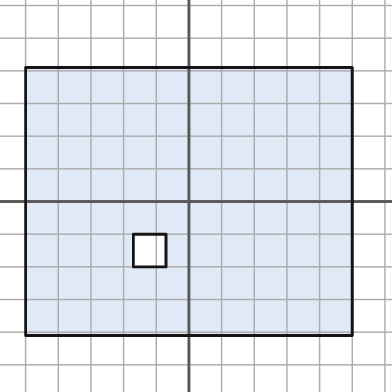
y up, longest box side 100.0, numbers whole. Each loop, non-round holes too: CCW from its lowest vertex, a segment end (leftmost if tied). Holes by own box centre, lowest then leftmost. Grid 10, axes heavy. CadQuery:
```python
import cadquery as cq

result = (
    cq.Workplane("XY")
    .moveTo(-50.0, -41.0)
    .lineTo(50.0, -41.0)
    .lineTo(50.0, 41.0)
    .lineTo(-50.0, 41.0)
    .close()
    .moveTo(-17.0, -20.0)
    .lineTo(-7.0, -20.0)
    .lineTo(-7.0, -10.0)
    .lineTo(-17.0, -10.0)
    .close()
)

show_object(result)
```